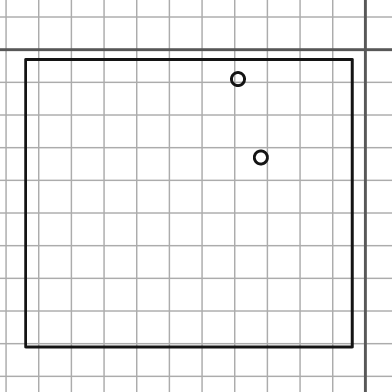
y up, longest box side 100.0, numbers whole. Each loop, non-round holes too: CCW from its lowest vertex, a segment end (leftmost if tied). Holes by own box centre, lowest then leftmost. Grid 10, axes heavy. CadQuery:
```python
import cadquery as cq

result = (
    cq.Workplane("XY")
    .moveTo(-104.0, -91.0)
    .lineTo(-4.0, -91.0)
    .lineTo(-4.0, -3.0)
    .lineTo(-104.0, -3.0)
    .close()
    .moveTo(-32.0, -33.0)
    .circle(2.0)
    .moveTo(-39.0, -9.0)
    .circle(2.0)
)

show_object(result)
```